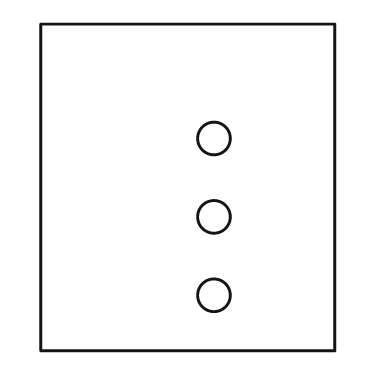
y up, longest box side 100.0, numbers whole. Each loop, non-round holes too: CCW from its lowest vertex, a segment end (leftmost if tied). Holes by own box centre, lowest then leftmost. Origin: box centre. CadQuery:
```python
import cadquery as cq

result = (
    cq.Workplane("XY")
    .moveTo(-45.0, -50.0)
    .lineTo(45.0, -50.0)
    .lineTo(45.0, 50.0)
    .lineTo(-45.0, 50.0)
    .close()
    .moveTo(8.0, -33.0)
    .circle(5.0)
    .moveTo(8.0, -9.0)
    .circle(5.0)
    .moveTo(8.0, 15.0)
    .circle(5.0)
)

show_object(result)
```